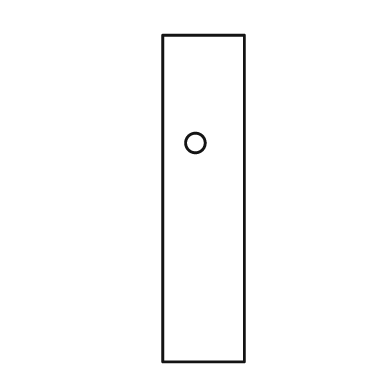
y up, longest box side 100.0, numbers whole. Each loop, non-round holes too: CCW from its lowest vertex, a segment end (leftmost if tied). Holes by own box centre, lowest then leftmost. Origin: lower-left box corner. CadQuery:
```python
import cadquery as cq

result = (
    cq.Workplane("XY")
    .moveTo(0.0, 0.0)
    .lineTo(25.0, 0.0)
    .lineTo(25.0, 100.0)
    .lineTo(0.0, 100.0)
    .close()
    .moveTo(10.0, 67.0)
    .circle(3.0)
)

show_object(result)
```